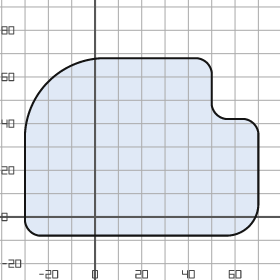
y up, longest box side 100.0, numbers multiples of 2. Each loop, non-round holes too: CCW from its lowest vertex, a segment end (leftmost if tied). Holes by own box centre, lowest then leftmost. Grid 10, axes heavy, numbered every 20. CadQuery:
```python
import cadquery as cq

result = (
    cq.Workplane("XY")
    .moveTo(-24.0, -8.0)
    .lineTo(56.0, -8.0)
    .threePointArc((66.0, -4.0), (70.0, 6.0))
    .lineTo(70.0, 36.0)
    .threePointArc((68.0, 40.0), (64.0, 42.0))
    .lineTo(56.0, 42.0)
    .threePointArc((52.0, 44.0), (50.0, 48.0))
    .lineTo(50.0, 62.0)
    .threePointArc((48.0, 66.0), (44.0, 68.0))
    .lineTo(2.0, 68.0)
    .threePointArc((-20.0, 58.0), (-30.0, 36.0))
    .lineTo(-30.0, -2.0)
    .threePointArc((-28.0, -6.0), (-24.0, -8.0))
    .close()
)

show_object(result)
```